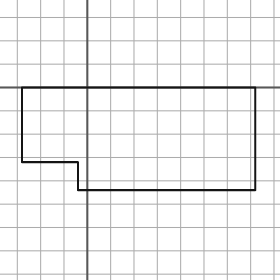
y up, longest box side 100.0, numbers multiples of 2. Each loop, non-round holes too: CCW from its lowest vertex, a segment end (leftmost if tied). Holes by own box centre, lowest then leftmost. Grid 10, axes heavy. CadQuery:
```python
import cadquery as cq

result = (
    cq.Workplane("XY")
    .moveTo(-4.0, -44.0)
    .lineTo(72.0, -44.0)
    .lineTo(72.0, 0.0)
    .lineTo(-28.0, 0.0)
    .lineTo(-28.0, -32.0)
    .lineTo(-4.0, -32.0)
    .close()
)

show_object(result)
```